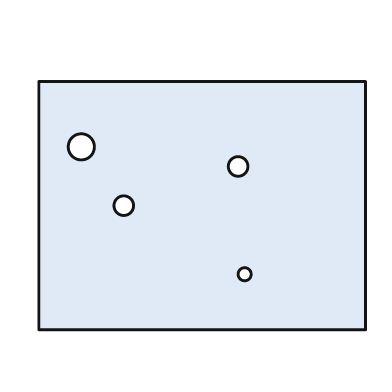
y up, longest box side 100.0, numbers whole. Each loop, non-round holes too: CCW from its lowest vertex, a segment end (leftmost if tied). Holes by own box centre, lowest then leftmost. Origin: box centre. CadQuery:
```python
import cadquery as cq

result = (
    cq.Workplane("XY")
    .moveTo(-50.0, -38.0)
    .lineTo(50.0, -38.0)
    .lineTo(50.0, 38.0)
    .lineTo(-50.0, 38.0)
    .close()
    .moveTo(13.0, -21.0)
    .circle(2.0)
    .moveTo(-24.0, 0.0)
    .circle(3.0)
    .moveTo(11.0, 12.0)
    .circle(3.0)
    .moveTo(-37.0, 18.0)
    .circle(4.0)
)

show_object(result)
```